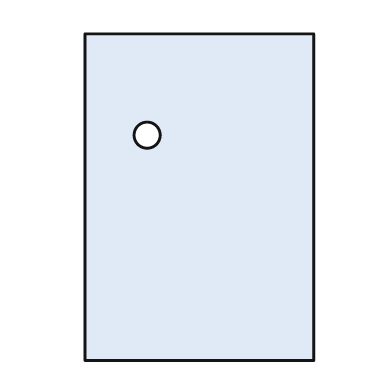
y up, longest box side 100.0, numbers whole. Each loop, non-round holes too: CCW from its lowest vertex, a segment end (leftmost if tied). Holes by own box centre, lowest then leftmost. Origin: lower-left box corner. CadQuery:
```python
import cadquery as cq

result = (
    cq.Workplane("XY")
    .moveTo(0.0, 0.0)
    .lineTo(70.0, 0.0)
    .lineTo(70.0, 100.0)
    .lineTo(0.0, 100.0)
    .close()
    .moveTo(19.0, 69.0)
    .circle(4.0)
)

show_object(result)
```